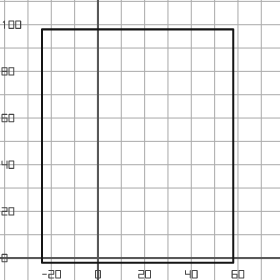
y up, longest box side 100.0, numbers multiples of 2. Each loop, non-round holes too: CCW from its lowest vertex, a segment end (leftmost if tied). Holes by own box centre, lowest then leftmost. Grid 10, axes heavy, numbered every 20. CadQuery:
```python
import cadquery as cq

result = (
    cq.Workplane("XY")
    .moveTo(-24.0, -2.0)
    .lineTo(58.0, -2.0)
    .lineTo(58.0, 98.0)
    .lineTo(-24.0, 98.0)
    .close()
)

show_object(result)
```